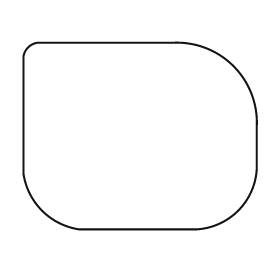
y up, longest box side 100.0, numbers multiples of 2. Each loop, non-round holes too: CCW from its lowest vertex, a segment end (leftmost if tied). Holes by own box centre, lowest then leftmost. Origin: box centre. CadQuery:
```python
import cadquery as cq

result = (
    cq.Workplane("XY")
    .moveTo(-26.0, -40.0)
    .lineTo(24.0, -40.0)
    .threePointArc((42.0, -32.0), (50.0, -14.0))
    .lineTo(50.0, 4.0)
    .threePointArc((40.0, 30.0), (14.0, 40.0))
    .lineTo(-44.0, 40.0)
    .threePointArc((-48.0, 38.0), (-50.0, 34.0))
    .lineTo(-50.0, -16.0)
    .threePointArc((-42.0, -32.0), (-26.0, -40.0))
    .close()
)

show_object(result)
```